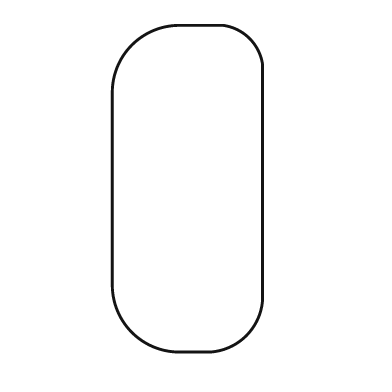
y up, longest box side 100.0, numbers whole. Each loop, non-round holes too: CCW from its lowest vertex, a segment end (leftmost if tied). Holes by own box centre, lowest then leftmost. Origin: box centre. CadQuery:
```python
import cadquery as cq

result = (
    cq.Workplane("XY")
    .moveTo(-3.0, -50.0)
    .lineTo(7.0, -50.0)
    .threePointArc((18.0, -45.0), (23.0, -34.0))
    .lineTo(23.0, 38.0)
    .threePointArc((19.0, 46.0), (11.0, 50.0))
    .lineTo(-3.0, 50.0)
    .threePointArc((-17.0, 44.0), (-23.0, 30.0))
    .lineTo(-23.0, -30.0)
    .threePointArc((-17.0, -44.0), (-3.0, -50.0))
    .close()
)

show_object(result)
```